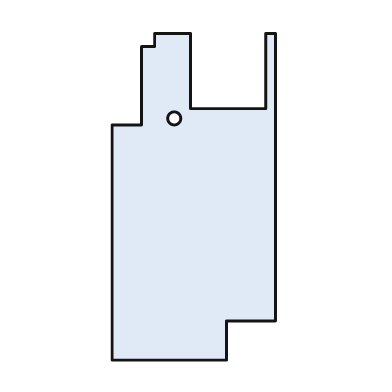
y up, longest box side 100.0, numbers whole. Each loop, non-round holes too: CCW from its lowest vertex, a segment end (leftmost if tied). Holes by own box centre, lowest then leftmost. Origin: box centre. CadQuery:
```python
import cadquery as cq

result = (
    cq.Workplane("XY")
    .moveTo(-25.0, -50.0)
    .lineTo(10.0, -50.0)
    .lineTo(10.0, -38.0)
    .lineTo(25.0, -38.0)
    .lineTo(25.0, 50.0)
    .lineTo(22.0, 50.0)
    .lineTo(22.0, 27.0)
    .lineTo(-1.0, 27.0)
    .lineTo(-1.0, 50.0)
    .lineTo(-12.0, 50.0)
    .lineTo(-12.0, 46.0)
    .lineTo(-16.0, 46.0)
    .lineTo(-16.0, 22.0)
    .lineTo(-25.0, 22.0)
    .close()
    .moveTo(-6.0, 24.0)
    .circle(2.0)
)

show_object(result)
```